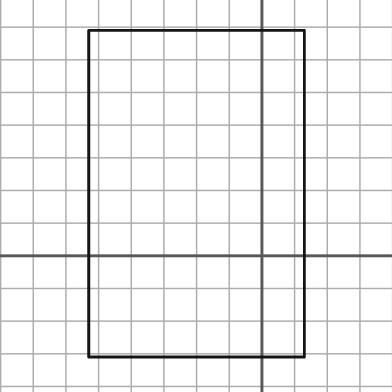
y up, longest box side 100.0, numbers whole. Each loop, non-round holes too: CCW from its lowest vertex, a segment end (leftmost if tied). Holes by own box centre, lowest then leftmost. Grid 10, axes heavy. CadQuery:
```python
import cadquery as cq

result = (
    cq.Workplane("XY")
    .moveTo(-53.0, -31.0)
    .lineTo(13.0, -31.0)
    .lineTo(13.0, 69.0)
    .lineTo(-53.0, 69.0)
    .close()
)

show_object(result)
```